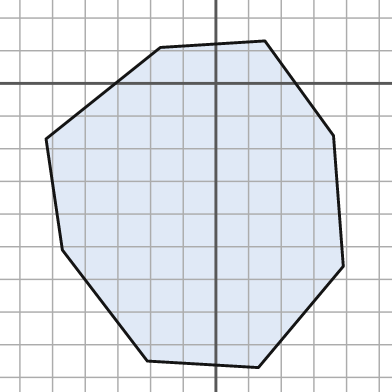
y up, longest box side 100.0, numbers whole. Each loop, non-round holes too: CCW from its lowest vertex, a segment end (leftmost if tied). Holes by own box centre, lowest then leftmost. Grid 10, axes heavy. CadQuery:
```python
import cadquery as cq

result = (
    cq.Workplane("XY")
    .moveTo(13.0, -87.0)
    .lineTo(39.0, -56.0)
    .lineTo(36.0, -16.0)
    .lineTo(15.0, 13.0)
    .lineTo(-17.0, 11.0)
    .lineTo(-52.0, -17.0)
    .lineTo(-47.0, -51.0)
    .lineTo(-21.0, -85.0)
    .close()
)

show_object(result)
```